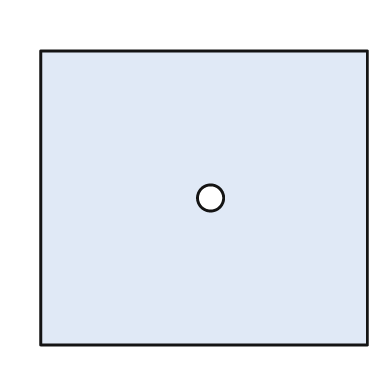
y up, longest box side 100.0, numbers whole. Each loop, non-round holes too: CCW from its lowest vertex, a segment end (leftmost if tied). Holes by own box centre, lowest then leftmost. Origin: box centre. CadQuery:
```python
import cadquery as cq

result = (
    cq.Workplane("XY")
    .moveTo(-50.0, -45.0)
    .lineTo(50.0, -45.0)
    .lineTo(50.0, 45.0)
    .lineTo(-50.0, 45.0)
    .close()
    .moveTo(2.0, 0.0)
    .circle(4.0)
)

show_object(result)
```